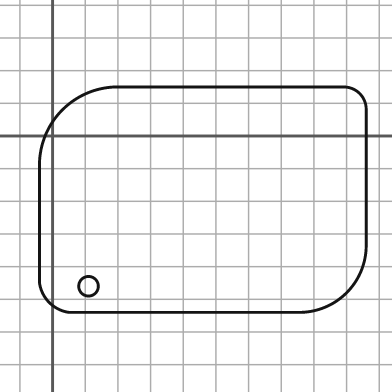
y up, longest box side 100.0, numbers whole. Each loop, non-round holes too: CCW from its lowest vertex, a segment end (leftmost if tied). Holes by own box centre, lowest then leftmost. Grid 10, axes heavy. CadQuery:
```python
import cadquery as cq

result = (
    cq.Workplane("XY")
    .moveTo(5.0, -54.0)
    .lineTo(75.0, -54.0)
    .threePointArc((90.0, -48.0), (96.0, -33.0))
    .lineTo(96.0, 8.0)
    .threePointArc((94.0, 13.0), (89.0, 15.0))
    .lineTo(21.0, 15.0)
    .threePointArc((3.0, 8.0), (-4.0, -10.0))
    .lineTo(-4.0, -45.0)
    .threePointArc((-1.0, -51.0), (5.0, -54.0))
    .close()
    .moveTo(11.0, -46.0)
    .circle(3.0)
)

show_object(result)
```